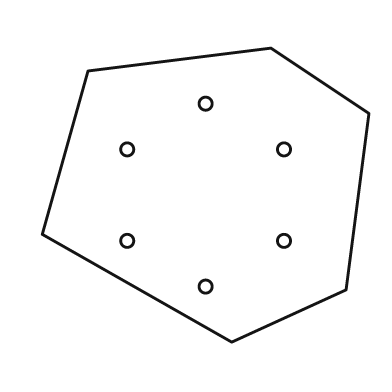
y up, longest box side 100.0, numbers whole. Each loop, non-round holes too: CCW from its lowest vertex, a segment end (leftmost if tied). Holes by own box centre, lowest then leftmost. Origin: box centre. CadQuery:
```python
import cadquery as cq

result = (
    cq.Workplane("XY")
    .moveTo(8.0, -45.0)
    .lineTo(43.0, -29.0)
    .lineTo(50.0, 25.0)
    .lineTo(20.0, 45.0)
    .lineTo(-36.0, 38.0)
    .lineTo(-50.0, -12.0)
    .close()
    .moveTo(0.0, -28.0)
    .circle(2.0)
    .moveTo(-24.0, -14.0)
    .circle(2.0)
    .moveTo(24.0, -14.0)
    .circle(2.0)
    .moveTo(-24.0, 14.0)
    .circle(2.0)
    .moveTo(24.0, 14.0)
    .circle(2.0)
    .moveTo(0.0, 28.0)
    .circle(2.0)
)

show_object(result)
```